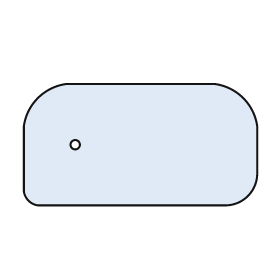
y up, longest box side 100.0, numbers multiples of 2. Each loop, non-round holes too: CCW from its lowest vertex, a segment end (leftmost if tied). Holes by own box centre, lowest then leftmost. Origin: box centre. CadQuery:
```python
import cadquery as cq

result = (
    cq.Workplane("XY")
    .moveTo(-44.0, -26.0)
    .lineTo(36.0, -26.0)
    .threePointArc((46.0, -22.0), (50.0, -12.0))
    .lineTo(50.0, 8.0)
    .threePointArc((44.0, 20.0), (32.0, 26.0))
    .lineTo(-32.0, 26.0)
    .threePointArc((-44.0, 20.0), (-50.0, 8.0))
    .lineTo(-50.0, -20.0)
    .threePointArc((-48.0, -24.0), (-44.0, -26.0))
    .close()
    .moveTo(-28.0, 0.0)
    .circle(2.0)
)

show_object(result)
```